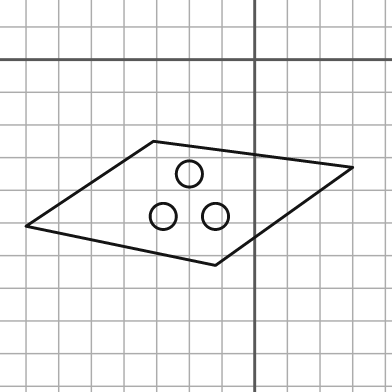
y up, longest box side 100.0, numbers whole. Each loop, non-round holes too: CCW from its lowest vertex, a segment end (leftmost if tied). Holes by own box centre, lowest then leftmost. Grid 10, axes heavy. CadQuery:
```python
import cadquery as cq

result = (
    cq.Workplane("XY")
    .moveTo(-12.0, -63.0)
    .lineTo(30.0, -33.0)
    .lineTo(-31.0, -25.0)
    .lineTo(-70.0, -51.0)
    .close()
    .moveTo(-28.0, -48.0)
    .circle(4.0)
    .moveTo(-12.0, -48.0)
    .circle(4.0)
    .moveTo(-20.0, -35.0)
    .circle(4.0)
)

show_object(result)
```